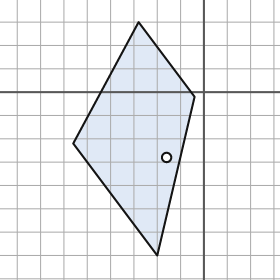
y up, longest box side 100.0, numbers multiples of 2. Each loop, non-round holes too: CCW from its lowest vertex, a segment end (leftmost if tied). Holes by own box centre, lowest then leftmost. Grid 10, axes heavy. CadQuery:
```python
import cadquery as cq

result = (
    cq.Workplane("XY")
    .moveTo(-20.0, -70.0)
    .lineTo(-4.0, -2.0)
    .lineTo(-28.0, 30.0)
    .lineTo(-56.0, -22.0)
    .close()
    .moveTo(-16.0, -28.0)
    .circle(2.0)
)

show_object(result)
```